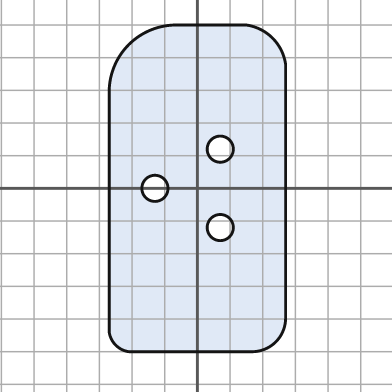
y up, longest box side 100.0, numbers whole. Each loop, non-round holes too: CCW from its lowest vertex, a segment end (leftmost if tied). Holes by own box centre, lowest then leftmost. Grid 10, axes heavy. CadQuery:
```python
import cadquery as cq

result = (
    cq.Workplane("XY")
    .moveTo(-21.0, -50.0)
    .lineTo(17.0, -50.0)
    .threePointArc((24.0, -47.0), (27.0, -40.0))
    .lineTo(27.0, 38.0)
    .threePointArc((23.0, 46.0), (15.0, 50.0))
    .lineTo(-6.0, 50.0)
    .threePointArc((-21.0, 44.0), (-27.0, 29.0))
    .lineTo(-27.0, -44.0)
    .threePointArc((-25.0, -48.0), (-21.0, -50.0))
    .close()
    .moveTo(7.0, -12.0)
    .circle(4.0)
    .moveTo(-13.0, 0.0)
    .circle(4.0)
    .moveTo(7.0, 12.0)
    .circle(4.0)
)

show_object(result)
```